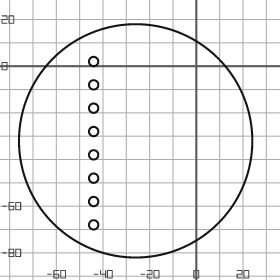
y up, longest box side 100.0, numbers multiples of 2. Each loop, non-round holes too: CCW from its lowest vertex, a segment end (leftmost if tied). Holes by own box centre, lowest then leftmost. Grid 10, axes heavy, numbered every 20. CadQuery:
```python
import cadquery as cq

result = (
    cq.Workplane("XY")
    .moveTo(-26.0, -32.0)
    .circle(50.0)
    .moveTo(-44.0, -68.0)
    .circle(2.0)
    .moveTo(-44.0, -58.0)
    .circle(2.0)
    .moveTo(-44.0, -48.0)
    .circle(2.0)
    .moveTo(-44.0, -38.0)
    .circle(2.0)
    .moveTo(-44.0, -28.0)
    .circle(2.0)
    .moveTo(-44.0, -18.0)
    .circle(2.0)
    .moveTo(-44.0, -8.0)
    .circle(2.0)
    .moveTo(-44.0, 2.0)
    .circle(2.0)
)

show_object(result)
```